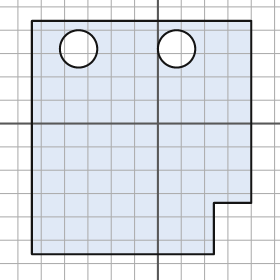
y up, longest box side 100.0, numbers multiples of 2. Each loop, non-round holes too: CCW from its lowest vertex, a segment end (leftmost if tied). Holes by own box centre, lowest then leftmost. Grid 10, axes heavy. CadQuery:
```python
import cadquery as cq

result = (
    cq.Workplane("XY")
    .moveTo(-54.0, -56.0)
    .lineTo(24.0, -56.0)
    .lineTo(24.0, -34.0)
    .lineTo(40.0, -34.0)
    .lineTo(40.0, 44.0)
    .lineTo(-54.0, 44.0)
    .close()
    .moveTo(-34.0, 32.0)
    .circle(8.0)
    .moveTo(8.0, 32.0)
    .circle(8.0)
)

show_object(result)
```